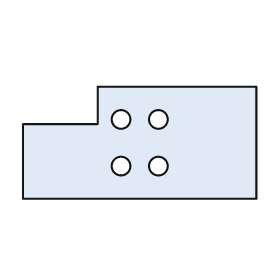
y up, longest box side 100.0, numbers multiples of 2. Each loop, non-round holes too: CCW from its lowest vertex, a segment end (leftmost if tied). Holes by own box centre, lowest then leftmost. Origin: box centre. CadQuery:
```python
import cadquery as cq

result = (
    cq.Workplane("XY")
    .moveTo(-50.0, -24.0)
    .lineTo(50.0, -24.0)
    .lineTo(50.0, 24.0)
    .lineTo(-18.0, 24.0)
    .lineTo(-18.0, 8.0)
    .lineTo(-50.0, 8.0)
    .close()
    .moveTo(-8.0, -10.0)
    .circle(4.0)
    .moveTo(8.0, -10.0)
    .circle(4.0)
    .moveTo(-8.0, 10.0)
    .circle(4.0)
    .moveTo(8.0, 10.0)
    .circle(4.0)
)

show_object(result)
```